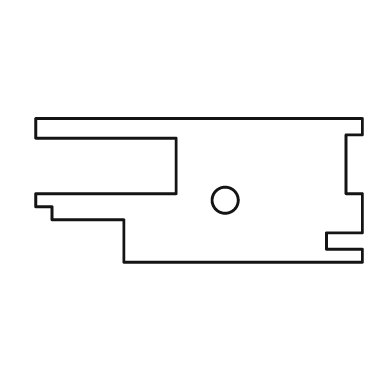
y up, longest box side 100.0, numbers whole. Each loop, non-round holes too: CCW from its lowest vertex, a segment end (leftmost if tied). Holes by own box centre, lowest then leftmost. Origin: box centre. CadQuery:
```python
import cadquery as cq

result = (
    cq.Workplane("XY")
    .moveTo(-23.0, -22.0)
    .lineTo(50.0, -22.0)
    .lineTo(50.0, -18.0)
    .lineTo(39.0, -18.0)
    .lineTo(39.0, -13.0)
    .lineTo(50.0, -13.0)
    .lineTo(50.0, -1.0)
    .lineTo(45.0, -1.0)
    .lineTo(45.0, 17.0)
    .lineTo(50.0, 17.0)
    .lineTo(50.0, 22.0)
    .lineTo(-50.0, 22.0)
    .lineTo(-50.0, 16.0)
    .lineTo(-7.0, 16.0)
    .lineTo(-7.0, -1.0)
    .lineTo(-50.0, -1.0)
    .lineTo(-50.0, -5.0)
    .lineTo(-45.0, -5.0)
    .lineTo(-45.0, -9.0)
    .lineTo(-23.0, -9.0)
    .close()
    .moveTo(8.0, -3.0)
    .circle(4.0)
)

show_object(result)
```